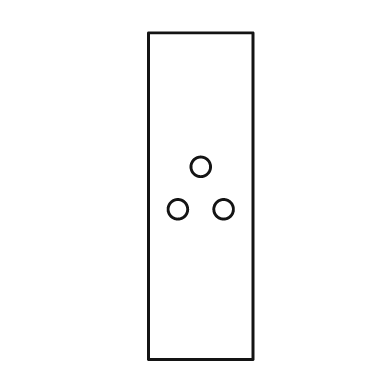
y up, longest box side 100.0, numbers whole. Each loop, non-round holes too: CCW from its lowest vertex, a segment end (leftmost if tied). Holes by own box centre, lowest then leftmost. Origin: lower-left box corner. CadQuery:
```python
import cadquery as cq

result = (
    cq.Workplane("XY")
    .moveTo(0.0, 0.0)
    .lineTo(32.0, 0.0)
    .lineTo(32.0, 100.0)
    .lineTo(0.0, 100.0)
    .close()
    .moveTo(9.0, 46.0)
    .circle(3.0)
    .moveTo(23.0, 46.0)
    .circle(3.0)
    .moveTo(16.0, 59.0)
    .circle(3.0)
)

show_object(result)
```